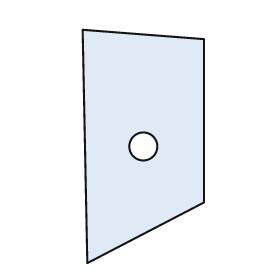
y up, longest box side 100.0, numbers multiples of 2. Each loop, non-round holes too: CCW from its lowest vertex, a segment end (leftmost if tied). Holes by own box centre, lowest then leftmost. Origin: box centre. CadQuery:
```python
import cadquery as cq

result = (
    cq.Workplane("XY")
    .moveTo(-24.0, -50.0)
    .lineTo(26.0, -24.0)
    .lineTo(26.0, 46.0)
    .lineTo(-26.0, 50.0)
    .close()
    .moveTo(0.0, 0.0)
    .circle(6.0)
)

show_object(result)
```